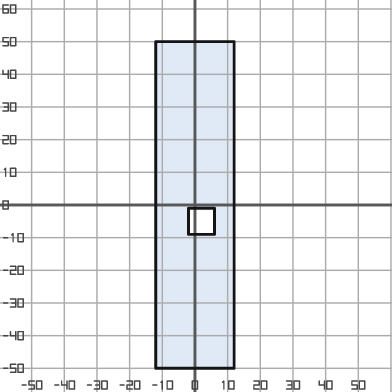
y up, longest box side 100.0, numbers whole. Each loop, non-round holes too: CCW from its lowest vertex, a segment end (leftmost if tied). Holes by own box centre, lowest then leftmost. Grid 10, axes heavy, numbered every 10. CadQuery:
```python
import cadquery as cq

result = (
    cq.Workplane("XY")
    .moveTo(-12.0, -50.0)
    .lineTo(12.0, -50.0)
    .lineTo(12.0, 50.0)
    .lineTo(-12.0, 50.0)
    .close()
    .moveTo(-2.0, -9.0)
    .lineTo(6.0, -9.0)
    .lineTo(6.0, -1.0)
    .lineTo(-2.0, -1.0)
    .close()
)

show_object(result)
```